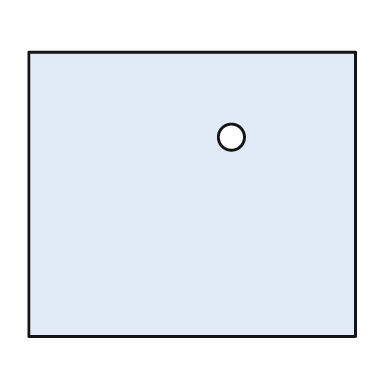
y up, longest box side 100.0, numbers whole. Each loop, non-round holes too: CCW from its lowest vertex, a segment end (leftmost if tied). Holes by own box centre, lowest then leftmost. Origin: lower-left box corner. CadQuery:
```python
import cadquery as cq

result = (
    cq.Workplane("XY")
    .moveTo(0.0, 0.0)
    .lineTo(100.0, 0.0)
    .lineTo(100.0, 87.0)
    .lineTo(0.0, 87.0)
    .close()
    .moveTo(62.0, 61.0)
    .circle(4.0)
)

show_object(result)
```